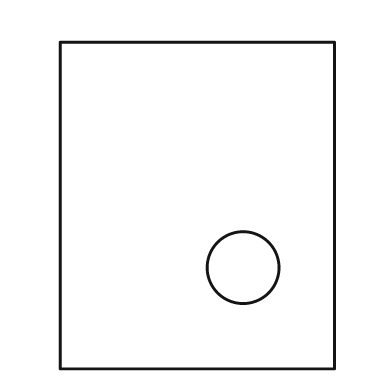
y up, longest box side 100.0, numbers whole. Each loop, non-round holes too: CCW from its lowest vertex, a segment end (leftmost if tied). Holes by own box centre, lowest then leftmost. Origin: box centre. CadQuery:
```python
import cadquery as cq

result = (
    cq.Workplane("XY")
    .moveTo(-42.0, -50.0)
    .lineTo(42.0, -50.0)
    .lineTo(42.0, 50.0)
    .lineTo(-42.0, 50.0)
    .close()
    .moveTo(14.0, -19.0)
    .circle(11.0)
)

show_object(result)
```